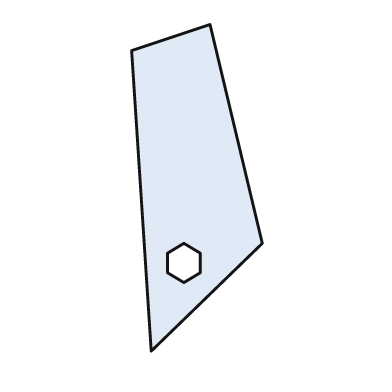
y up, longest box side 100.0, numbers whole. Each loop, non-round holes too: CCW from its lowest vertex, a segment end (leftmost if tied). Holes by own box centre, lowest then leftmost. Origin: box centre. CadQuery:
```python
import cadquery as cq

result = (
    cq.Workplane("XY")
    .moveTo(-14.0, -50.0)
    .lineTo(20.0, -17.0)
    .lineTo(4.0, 50.0)
    .lineTo(-20.0, 42.0)
    .close()
    .moveTo(-4.0, -29.0)
    .lineTo(1.0, -26.0)
    .lineTo(1.0, -20.0)
    .lineTo(-4.0, -17.0)
    .lineTo(-9.0, -20.0)
    .lineTo(-9.0, -26.0)
    .close()
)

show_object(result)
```